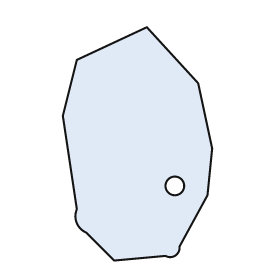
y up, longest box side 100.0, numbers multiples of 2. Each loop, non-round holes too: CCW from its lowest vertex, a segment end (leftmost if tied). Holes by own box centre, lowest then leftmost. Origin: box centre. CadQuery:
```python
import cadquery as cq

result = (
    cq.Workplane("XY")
    .moveTo(-10.0, -50.0)
    .lineTo(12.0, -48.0)
    .threePointArc((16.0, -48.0), (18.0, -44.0))
    .lineTo(30.0, -22.0)
    .lineTo(32.0, -2.0)
    .lineTo(26.0, 26.0)
    .lineTo(4.0, 50.0)
    .lineTo(-26.0, 36.0)
    .lineTo(-32.0, 12.0)
    .lineTo(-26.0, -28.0)
    .threePointArc((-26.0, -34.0), (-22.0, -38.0))
    .close()
    .moveTo(16.0, -18.0)
    .circle(4.0)
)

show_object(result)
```